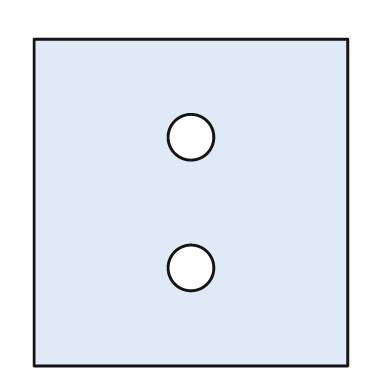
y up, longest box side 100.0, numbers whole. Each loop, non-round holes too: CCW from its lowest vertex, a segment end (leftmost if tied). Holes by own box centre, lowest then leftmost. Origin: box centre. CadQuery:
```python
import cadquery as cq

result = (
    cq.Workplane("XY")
    .moveTo(-48.0, -50.0)
    .lineTo(48.0, -50.0)
    .lineTo(48.0, 50.0)
    .lineTo(-48.0, 50.0)
    .close()
    .moveTo(0.0, -20.0)
    .circle(7.0)
    .moveTo(0.0, 20.0)
    .circle(7.0)
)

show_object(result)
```